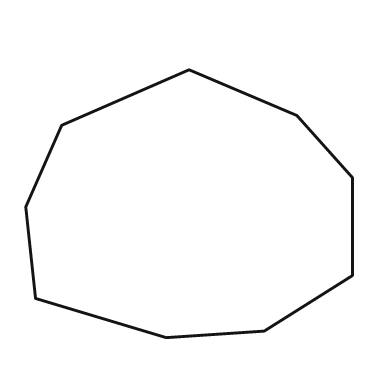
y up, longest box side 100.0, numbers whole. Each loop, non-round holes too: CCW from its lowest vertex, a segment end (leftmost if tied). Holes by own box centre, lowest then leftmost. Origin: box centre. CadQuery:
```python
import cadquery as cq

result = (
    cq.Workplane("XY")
    .moveTo(-7.0, -41.0)
    .lineTo(23.0, -39.0)
    .lineTo(50.0, -22.0)
    .lineTo(50.0, 8.0)
    .lineTo(33.0, 27.0)
    .lineTo(0.0, 41.0)
    .lineTo(-39.0, 24.0)
    .lineTo(-50.0, -1.0)
    .lineTo(-47.0, -29.0)
    .close()
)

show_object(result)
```